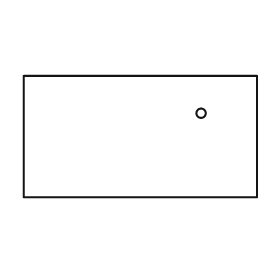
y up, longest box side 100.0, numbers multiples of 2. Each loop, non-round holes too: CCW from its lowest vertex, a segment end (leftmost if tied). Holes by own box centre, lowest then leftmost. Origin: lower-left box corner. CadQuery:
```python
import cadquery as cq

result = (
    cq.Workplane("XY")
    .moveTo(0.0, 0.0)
    .lineTo(100.0, 0.0)
    .lineTo(100.0, 52.0)
    .lineTo(0.0, 52.0)
    .close()
    .moveTo(76.0, 36.0)
    .circle(2.0)
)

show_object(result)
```